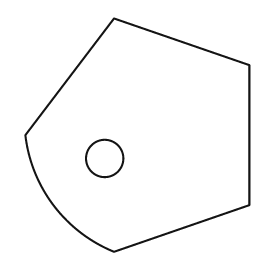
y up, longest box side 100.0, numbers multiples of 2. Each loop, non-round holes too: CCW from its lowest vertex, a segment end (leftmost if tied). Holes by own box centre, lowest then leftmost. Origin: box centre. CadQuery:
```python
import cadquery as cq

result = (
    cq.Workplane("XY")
    .moveTo(-10.0, -50.0)
    .lineTo(48.0, -30.0)
    .lineTo(48.0, 30.0)
    .lineTo(-10.0, 50.0)
    .lineTo(-48.0, 0.0)
    .threePointArc((-36.0, -30.0), (-10.0, -50.0))
    .close()
    .moveTo(-14.0, -10.0)
    .circle(8.0)
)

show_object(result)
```